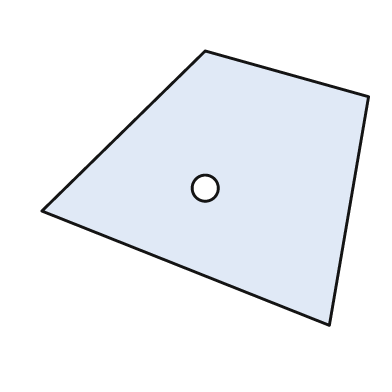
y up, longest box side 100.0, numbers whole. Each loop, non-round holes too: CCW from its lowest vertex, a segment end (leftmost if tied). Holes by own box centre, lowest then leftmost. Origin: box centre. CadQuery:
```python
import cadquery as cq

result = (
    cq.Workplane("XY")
    .moveTo(38.0, -42.0)
    .lineTo(50.0, 28.0)
    .lineTo(0.0, 42.0)
    .lineTo(-50.0, -7.0)
    .close()
    .moveTo(0.0, 0.0)
    .circle(4.0)
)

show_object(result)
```